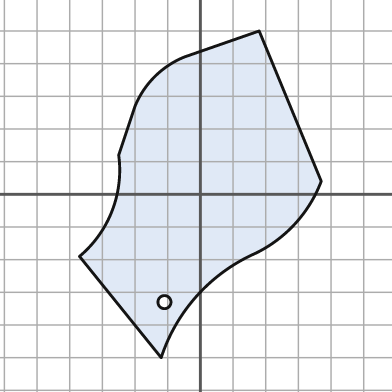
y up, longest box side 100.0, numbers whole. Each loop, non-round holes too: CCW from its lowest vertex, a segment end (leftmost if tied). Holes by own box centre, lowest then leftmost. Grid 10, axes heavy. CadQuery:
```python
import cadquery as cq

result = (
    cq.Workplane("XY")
    .moveTo(-12.0, -50.0)
    .threePointArc((-1.0, -31.0), (17.0, -18.0))
    .threePointArc((29.0, -9.0), (37.0, 4.0))
    .lineTo(18.0, 50.0)
    .lineTo(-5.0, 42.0)
    .threePointArc((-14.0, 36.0), (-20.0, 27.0))
    .lineTo(-25.0, 12.0)
    .threePointArc((-27.0, -5.0), (-37.0, -19.0))
    .close()
    .moveTo(-11.0, -33.0)
    .circle(2.0)
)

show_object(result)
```